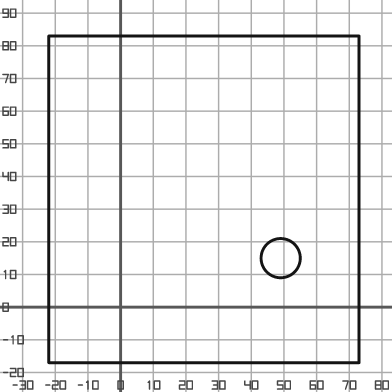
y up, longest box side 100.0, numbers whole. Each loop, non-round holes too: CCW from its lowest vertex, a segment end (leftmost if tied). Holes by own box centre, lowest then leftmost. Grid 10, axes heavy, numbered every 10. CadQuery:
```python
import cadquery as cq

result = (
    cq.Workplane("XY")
    .moveTo(-22.0, -17.0)
    .lineTo(73.0, -17.0)
    .lineTo(73.0, 83.0)
    .lineTo(-22.0, 83.0)
    .close()
    .moveTo(49.0, 15.0)
    .circle(6.0)
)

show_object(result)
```